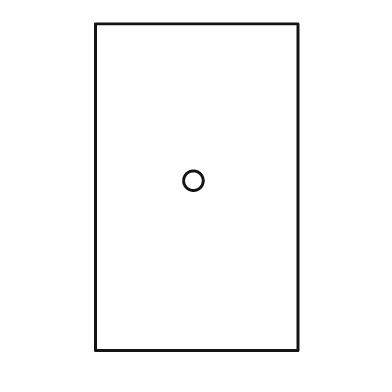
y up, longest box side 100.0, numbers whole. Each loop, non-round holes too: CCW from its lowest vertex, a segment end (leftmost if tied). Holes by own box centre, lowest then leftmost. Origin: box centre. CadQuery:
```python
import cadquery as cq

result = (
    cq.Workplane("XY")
    .moveTo(-31.0, -50.0)
    .lineTo(31.0, -50.0)
    .lineTo(31.0, 50.0)
    .lineTo(-31.0, 50.0)
    .close()
    .moveTo(-1.0, 2.0)
    .circle(3.0)
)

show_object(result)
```